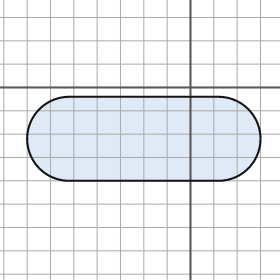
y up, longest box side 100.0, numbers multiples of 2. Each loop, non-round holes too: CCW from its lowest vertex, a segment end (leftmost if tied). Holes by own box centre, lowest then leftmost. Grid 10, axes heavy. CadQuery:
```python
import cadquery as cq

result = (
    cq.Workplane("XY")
    .moveTo(-52.0, -40.0)
    .lineTo(12.0, -40.0)
    .threePointArc((30.0, -22.0), (12.0, -4.0))
    .lineTo(-52.0, -4.0)
    .threePointArc((-70.0, -22.0), (-52.0, -40.0))
    .close()
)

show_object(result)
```